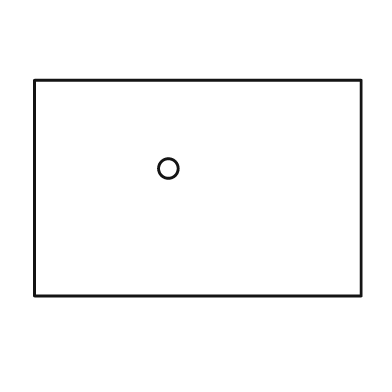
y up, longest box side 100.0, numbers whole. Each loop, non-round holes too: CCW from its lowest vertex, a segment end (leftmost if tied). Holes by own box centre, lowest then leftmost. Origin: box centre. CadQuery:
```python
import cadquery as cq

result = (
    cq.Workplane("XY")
    .moveTo(-50.0, -33.0)
    .lineTo(50.0, -33.0)
    .lineTo(50.0, 33.0)
    .lineTo(-50.0, 33.0)
    .close()
    .moveTo(-9.0, 6.0)
    .circle(3.0)
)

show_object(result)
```